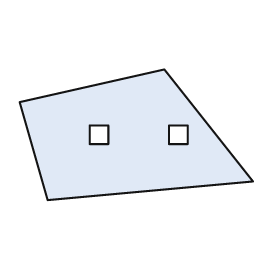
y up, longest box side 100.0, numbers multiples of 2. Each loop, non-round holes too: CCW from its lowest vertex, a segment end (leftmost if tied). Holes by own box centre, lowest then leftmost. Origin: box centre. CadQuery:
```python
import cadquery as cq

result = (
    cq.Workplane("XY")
    .moveTo(-38.0, -28.0)
    .lineTo(50.0, -20.0)
    .lineTo(12.0, 28.0)
    .lineTo(-50.0, 14.0)
    .close()
    .moveTo(-20.0, -4.0)
    .lineTo(-12.0, -4.0)
    .lineTo(-12.0, 4.0)
    .lineTo(-20.0, 4.0)
    .close()
    .moveTo(14.0, -4.0)
    .lineTo(22.0, -4.0)
    .lineTo(22.0, 4.0)
    .lineTo(14.0, 4.0)
    .close()
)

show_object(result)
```